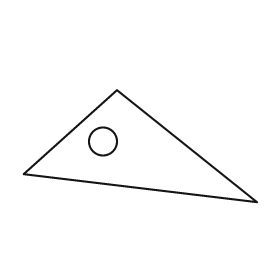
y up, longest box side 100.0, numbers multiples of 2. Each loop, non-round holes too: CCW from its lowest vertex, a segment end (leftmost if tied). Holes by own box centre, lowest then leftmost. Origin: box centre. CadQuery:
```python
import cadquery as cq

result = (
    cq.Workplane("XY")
    .moveTo(50.0, -24.0)
    .lineTo(-10.0, 24.0)
    .lineTo(-50.0, -12.0)
    .close()
    .moveTo(-16.0, 2.0)
    .circle(6.0)
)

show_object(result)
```